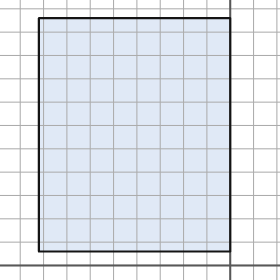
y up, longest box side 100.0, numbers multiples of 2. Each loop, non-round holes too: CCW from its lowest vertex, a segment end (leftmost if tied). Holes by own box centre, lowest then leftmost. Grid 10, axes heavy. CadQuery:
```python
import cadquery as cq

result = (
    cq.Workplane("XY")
    .moveTo(-82.0, 6.0)
    .lineTo(0.0, 6.0)
    .lineTo(0.0, 106.0)
    .lineTo(-82.0, 106.0)
    .close()
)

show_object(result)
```